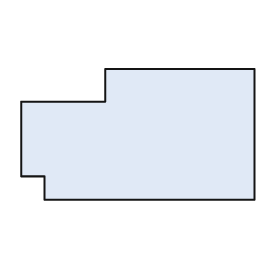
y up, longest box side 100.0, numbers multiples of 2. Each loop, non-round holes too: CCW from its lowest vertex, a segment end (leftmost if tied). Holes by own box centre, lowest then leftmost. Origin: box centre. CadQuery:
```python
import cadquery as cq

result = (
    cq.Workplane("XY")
    .moveTo(-40.0, -28.0)
    .lineTo(50.0, -28.0)
    .lineTo(50.0, 28.0)
    .lineTo(-14.0, 28.0)
    .lineTo(-14.0, 14.0)
    .lineTo(-50.0, 14.0)
    .lineTo(-50.0, -18.0)
    .lineTo(-40.0, -18.0)
    .close()
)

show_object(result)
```